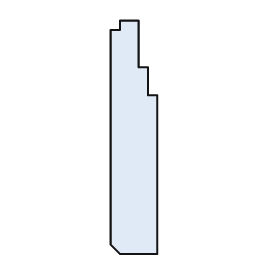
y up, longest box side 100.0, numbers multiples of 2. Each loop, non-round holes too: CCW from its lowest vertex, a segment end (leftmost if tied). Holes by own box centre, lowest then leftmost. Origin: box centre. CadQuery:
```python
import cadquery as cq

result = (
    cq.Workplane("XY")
    .moveTo(-6.0, -50.0)
    .lineTo(10.0, -50.0)
    .lineTo(10.0, 18.0)
    .lineTo(6.0, 18.0)
    .lineTo(6.0, 30.0)
    .lineTo(2.0, 30.0)
    .lineTo(2.0, 50.0)
    .lineTo(-6.0, 50.0)
    .lineTo(-6.0, 46.0)
    .lineTo(-10.0, 46.0)
    .lineTo(-10.0, -46.0)
    .close()
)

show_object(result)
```